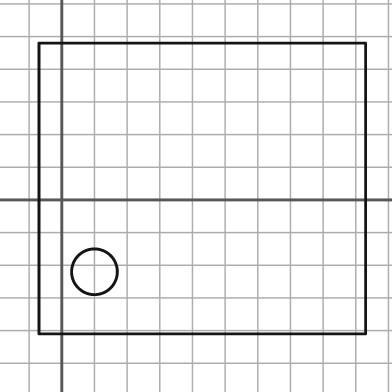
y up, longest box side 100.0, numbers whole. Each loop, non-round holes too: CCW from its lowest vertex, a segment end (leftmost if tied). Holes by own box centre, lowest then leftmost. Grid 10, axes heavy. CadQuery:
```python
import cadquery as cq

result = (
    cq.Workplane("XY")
    .moveTo(-7.0, -41.0)
    .lineTo(93.0, -41.0)
    .lineTo(93.0, 48.0)
    .lineTo(-7.0, 48.0)
    .close()
    .moveTo(10.0, -22.0)
    .circle(7.0)
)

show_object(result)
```